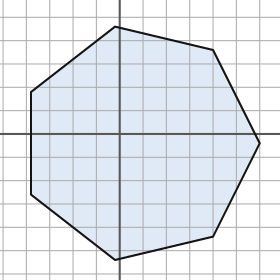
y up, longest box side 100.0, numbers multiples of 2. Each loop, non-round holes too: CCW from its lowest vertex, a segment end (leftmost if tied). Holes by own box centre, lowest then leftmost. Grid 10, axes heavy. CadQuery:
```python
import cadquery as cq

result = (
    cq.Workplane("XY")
    .moveTo(-2.0, -54.0)
    .lineTo(40.0, -44.0)
    .lineTo(60.0, -4.0)
    .lineTo(40.0, 36.0)
    .lineTo(-2.0, 46.0)
    .lineTo(-38.0, 18.0)
    .lineTo(-38.0, -26.0)
    .close()
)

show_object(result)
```